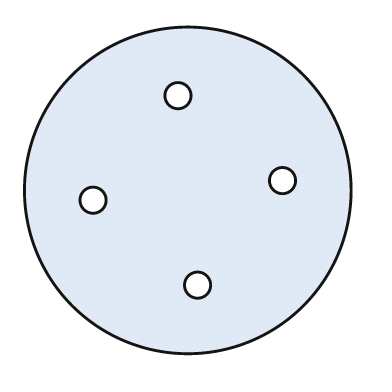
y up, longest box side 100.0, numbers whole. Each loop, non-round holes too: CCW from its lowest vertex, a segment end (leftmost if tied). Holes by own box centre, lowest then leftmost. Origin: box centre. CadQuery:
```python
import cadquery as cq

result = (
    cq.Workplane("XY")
    .moveTo(0.0, 0.0)
    .circle(50.0)
    .moveTo(3.0, -29.0)
    .circle(4.0)
    .moveTo(-29.0, -3.0)
    .circle(4.0)
    .moveTo(29.0, 3.0)
    .circle(4.0)
    .moveTo(-3.0, 29.0)
    .circle(4.0)
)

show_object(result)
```